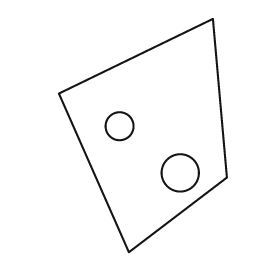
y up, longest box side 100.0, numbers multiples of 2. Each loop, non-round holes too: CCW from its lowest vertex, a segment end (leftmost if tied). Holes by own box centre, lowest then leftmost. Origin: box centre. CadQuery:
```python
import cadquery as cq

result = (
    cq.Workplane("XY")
    .moveTo(-6.0, -50.0)
    .lineTo(36.0, -18.0)
    .lineTo(30.0, 50.0)
    .lineTo(-36.0, 18.0)
    .close()
    .moveTo(16.0, -16.0)
    .circle(8.0)
    .moveTo(-10.0, 4.0)
    .circle(6.0)
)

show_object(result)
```